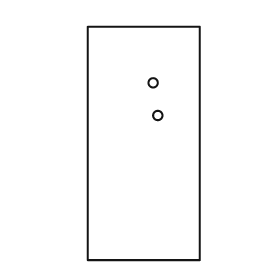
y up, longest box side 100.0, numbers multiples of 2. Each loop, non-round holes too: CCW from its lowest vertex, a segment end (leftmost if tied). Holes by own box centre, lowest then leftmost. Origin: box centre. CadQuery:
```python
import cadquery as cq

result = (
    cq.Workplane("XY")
    .moveTo(-24.0, -50.0)
    .lineTo(24.0, -50.0)
    .lineTo(24.0, 50.0)
    .lineTo(-24.0, 50.0)
    .close()
    .moveTo(6.0, 12.0)
    .circle(2.0)
    .moveTo(4.0, 26.0)
    .circle(2.0)
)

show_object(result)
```